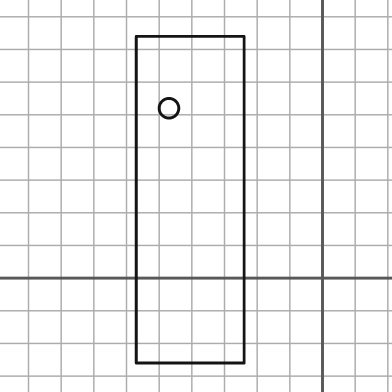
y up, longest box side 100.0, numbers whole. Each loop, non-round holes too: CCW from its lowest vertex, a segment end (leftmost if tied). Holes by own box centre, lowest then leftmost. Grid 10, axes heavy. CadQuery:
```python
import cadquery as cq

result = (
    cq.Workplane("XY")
    .moveTo(-57.0, -26.0)
    .lineTo(-24.0, -26.0)
    .lineTo(-24.0, 74.0)
    .lineTo(-57.0, 74.0)
    .close()
    .moveTo(-47.0, 52.0)
    .circle(3.0)
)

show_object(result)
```